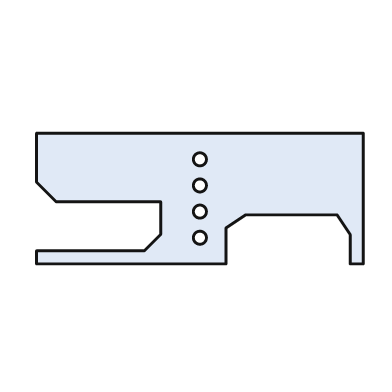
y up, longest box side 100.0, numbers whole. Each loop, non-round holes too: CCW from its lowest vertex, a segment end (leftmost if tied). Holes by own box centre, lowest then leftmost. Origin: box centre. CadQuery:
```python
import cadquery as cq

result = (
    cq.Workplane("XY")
    .moveTo(-50.0, -20.0)
    .lineTo(8.0, -20.0)
    .lineTo(8.0, -9.0)
    .lineTo(14.0, -5.0)
    .lineTo(42.0, -5.0)
    .lineTo(46.0, -11.0)
    .lineTo(46.0, -20.0)
    .lineTo(50.0, -20.0)
    .lineTo(50.0, 20.0)
    .lineTo(-50.0, 20.0)
    .lineTo(-50.0, 5.0)
    .lineTo(-44.0, -1.0)
    .lineTo(-12.0, -1.0)
    .lineTo(-12.0, -11.0)
    .lineTo(-17.0, -16.0)
    .lineTo(-50.0, -16.0)
    .close()
    .moveTo(0.0, -12.0)
    .circle(2.0)
    .moveTo(0.0, -4.0)
    .circle(2.0)
    .moveTo(0.0, 4.0)
    .circle(2.0)
    .moveTo(0.0, 12.0)
    .circle(2.0)
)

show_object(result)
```